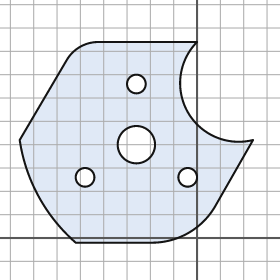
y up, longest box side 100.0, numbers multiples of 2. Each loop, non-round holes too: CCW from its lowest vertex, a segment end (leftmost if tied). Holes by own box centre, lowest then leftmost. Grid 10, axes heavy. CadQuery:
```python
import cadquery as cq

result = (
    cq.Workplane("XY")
    .moveTo(-52.0, -2.0)
    .lineTo(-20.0, -2.0)
    .threePointArc((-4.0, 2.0), (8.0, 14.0))
    .lineTo(24.0, 42.0)
    .threePointArc((-4.0, 54.0), (0.0, 84.0))
    .lineTo(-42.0, 84.0)
    .threePointArc((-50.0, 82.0), (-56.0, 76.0))
    .lineTo(-76.0, 42.0)
    .threePointArc((-68.0, 18.0), (-52.0, -2.0))
    .close()
    .moveTo(-48.0, 26.0)
    .circle(4.0)
    .moveTo(-4.0, 26.0)
    .circle(4.0)
    .moveTo(-26.0, 40.0)
    .circle(8.0)
    .moveTo(-26.0, 66.0)
    .circle(4.0)
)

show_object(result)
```